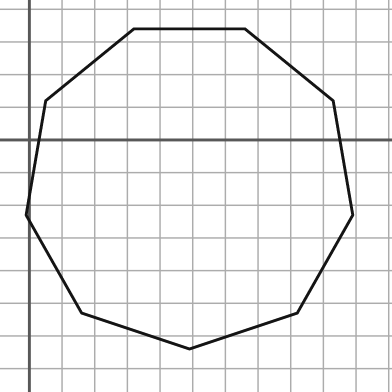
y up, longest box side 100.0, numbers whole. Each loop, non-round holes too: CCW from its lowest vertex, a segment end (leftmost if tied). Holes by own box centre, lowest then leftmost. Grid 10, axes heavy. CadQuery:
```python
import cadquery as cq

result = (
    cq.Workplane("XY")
    .moveTo(49.0, -64.0)
    .lineTo(82.0, -53.0)
    .lineTo(99.0, -23.0)
    .lineTo(93.0, 12.0)
    .lineTo(66.0, 34.0)
    .lineTo(32.0, 34.0)
    .lineTo(5.0, 12.0)
    .lineTo(-1.0, -23.0)
    .lineTo(16.0, -53.0)
    .close()
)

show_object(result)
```